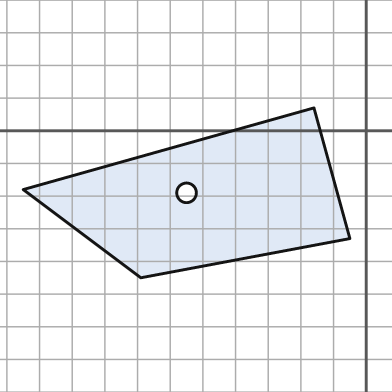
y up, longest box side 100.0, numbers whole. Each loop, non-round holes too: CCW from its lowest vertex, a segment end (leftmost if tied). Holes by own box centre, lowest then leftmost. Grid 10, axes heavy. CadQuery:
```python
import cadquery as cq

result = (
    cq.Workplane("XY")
    .moveTo(-69.0, -45.0)
    .lineTo(-5.0, -33.0)
    .lineTo(-16.0, 7.0)
    .lineTo(-105.0, -18.0)
    .close()
    .moveTo(-55.0, -19.0)
    .circle(3.0)
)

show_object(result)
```